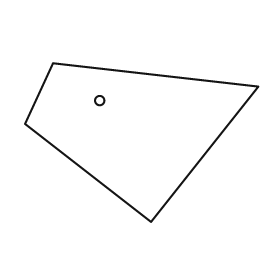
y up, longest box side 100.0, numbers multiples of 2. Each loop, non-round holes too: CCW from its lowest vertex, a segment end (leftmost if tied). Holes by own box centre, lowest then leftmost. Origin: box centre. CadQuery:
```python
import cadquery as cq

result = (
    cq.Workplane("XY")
    .moveTo(4.0, -34.0)
    .lineTo(50.0, 24.0)
    .lineTo(-38.0, 34.0)
    .lineTo(-50.0, 8.0)
    .close()
    .moveTo(-18.0, 18.0)
    .circle(2.0)
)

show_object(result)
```